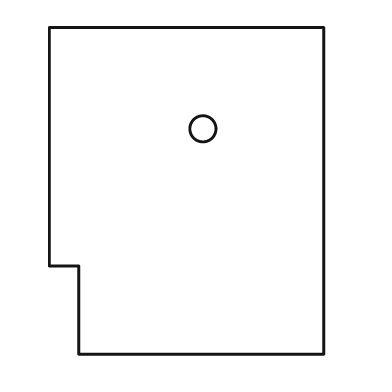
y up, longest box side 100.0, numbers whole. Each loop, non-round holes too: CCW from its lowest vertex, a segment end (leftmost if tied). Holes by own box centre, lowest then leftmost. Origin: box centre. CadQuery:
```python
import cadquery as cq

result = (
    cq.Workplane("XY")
    .moveTo(-33.0, -50.0)
    .lineTo(42.0, -50.0)
    .lineTo(42.0, 50.0)
    .lineTo(-42.0, 50.0)
    .lineTo(-42.0, -23.0)
    .lineTo(-33.0, -23.0)
    .close()
    .moveTo(5.0, 19.0)
    .circle(4.0)
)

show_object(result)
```